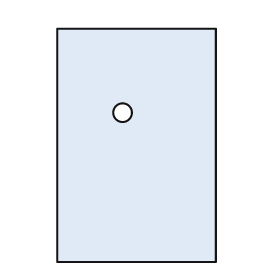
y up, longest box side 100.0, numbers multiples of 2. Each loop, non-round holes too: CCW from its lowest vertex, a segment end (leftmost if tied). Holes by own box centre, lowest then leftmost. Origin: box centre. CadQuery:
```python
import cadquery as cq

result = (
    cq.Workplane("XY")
    .moveTo(-34.0, -50.0)
    .lineTo(34.0, -50.0)
    .lineTo(34.0, 50.0)
    .lineTo(-34.0, 50.0)
    .close()
    .moveTo(-6.0, 14.0)
    .circle(4.0)
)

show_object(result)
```